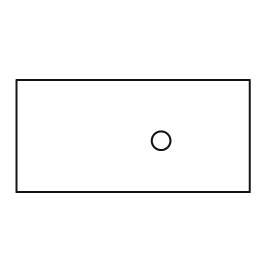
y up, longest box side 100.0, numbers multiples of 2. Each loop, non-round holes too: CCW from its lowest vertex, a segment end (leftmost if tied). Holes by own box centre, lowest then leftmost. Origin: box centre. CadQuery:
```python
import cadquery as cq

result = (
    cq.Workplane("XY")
    .moveTo(-50.0, -24.0)
    .lineTo(50.0, -24.0)
    .lineTo(50.0, 24.0)
    .lineTo(-50.0, 24.0)
    .close()
    .moveTo(12.0, -2.0)
    .circle(4.0)
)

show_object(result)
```